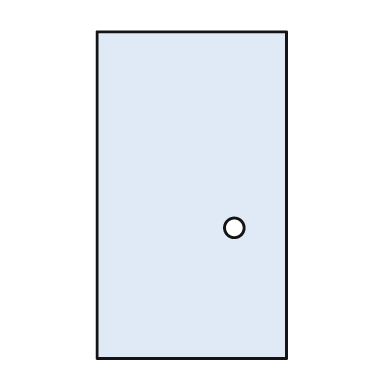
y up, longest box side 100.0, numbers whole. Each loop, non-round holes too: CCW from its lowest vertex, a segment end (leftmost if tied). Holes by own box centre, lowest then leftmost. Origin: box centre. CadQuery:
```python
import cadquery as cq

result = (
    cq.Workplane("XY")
    .moveTo(-29.0, -50.0)
    .lineTo(29.0, -50.0)
    .lineTo(29.0, 50.0)
    .lineTo(-29.0, 50.0)
    .close()
    .moveTo(13.0, -10.0)
    .circle(3.0)
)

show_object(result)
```